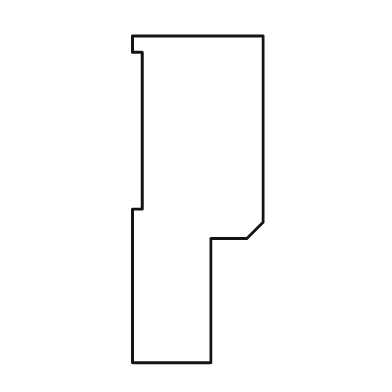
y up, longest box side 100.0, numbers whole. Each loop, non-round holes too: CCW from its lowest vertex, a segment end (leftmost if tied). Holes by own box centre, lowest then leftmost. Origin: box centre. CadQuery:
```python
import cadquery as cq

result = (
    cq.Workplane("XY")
    .moveTo(-20.0, -50.0)
    .lineTo(4.0, -50.0)
    .lineTo(4.0, -12.0)
    .lineTo(15.0, -12.0)
    .lineTo(20.0, -7.0)
    .lineTo(20.0, 50.0)
    .lineTo(-20.0, 50.0)
    .lineTo(-20.0, 45.0)
    .lineTo(-17.0, 45.0)
    .lineTo(-17.0, -3.0)
    .lineTo(-20.0, -3.0)
    .close()
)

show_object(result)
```